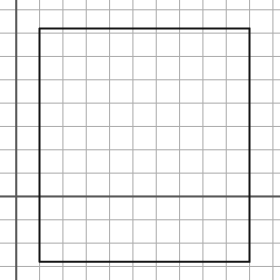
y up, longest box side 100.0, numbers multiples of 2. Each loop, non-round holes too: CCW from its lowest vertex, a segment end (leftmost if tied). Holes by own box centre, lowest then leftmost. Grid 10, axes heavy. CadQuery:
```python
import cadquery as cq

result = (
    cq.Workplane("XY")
    .moveTo(10.0, -28.0)
    .lineTo(100.0, -28.0)
    .lineTo(100.0, 72.0)
    .lineTo(10.0, 72.0)
    .close()
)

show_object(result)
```